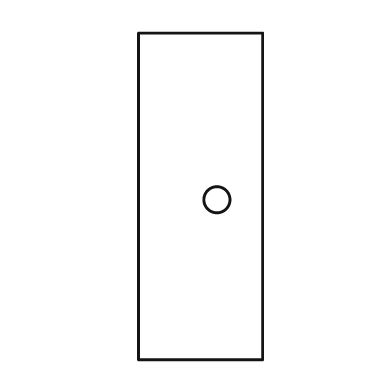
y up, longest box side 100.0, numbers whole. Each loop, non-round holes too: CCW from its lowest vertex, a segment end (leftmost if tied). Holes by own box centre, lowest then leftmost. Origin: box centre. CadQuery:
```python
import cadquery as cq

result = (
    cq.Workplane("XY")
    .moveTo(-19.0, -50.0)
    .lineTo(19.0, -50.0)
    .lineTo(19.0, 50.0)
    .lineTo(-19.0, 50.0)
    .close()
    .moveTo(5.0, -1.0)
    .circle(4.0)
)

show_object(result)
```